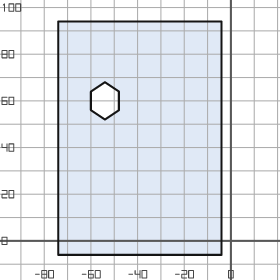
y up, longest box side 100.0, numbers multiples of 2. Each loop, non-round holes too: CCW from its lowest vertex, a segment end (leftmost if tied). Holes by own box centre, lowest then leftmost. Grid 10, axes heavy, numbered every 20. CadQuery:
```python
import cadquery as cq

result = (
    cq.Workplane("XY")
    .moveTo(-74.0, -6.0)
    .lineTo(-4.0, -6.0)
    .lineTo(-4.0, 94.0)
    .lineTo(-74.0, 94.0)
    .close()
    .moveTo(-54.0, 52.0)
    .lineTo(-48.0, 56.0)
    .lineTo(-48.0, 64.0)
    .lineTo(-54.0, 68.0)
    .lineTo(-60.0, 64.0)
    .lineTo(-60.0, 56.0)
    .close()
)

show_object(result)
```